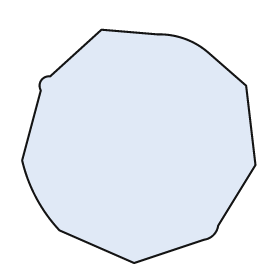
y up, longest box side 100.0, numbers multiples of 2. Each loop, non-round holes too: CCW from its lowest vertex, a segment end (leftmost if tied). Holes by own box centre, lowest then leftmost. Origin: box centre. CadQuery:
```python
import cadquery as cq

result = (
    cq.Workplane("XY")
    .moveTo(-2.0, -50.0)
    .lineTo(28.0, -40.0)
    .threePointArc((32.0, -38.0), (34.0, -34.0))
    .lineTo(50.0, -8.0)
    .lineTo(46.0, 26.0)
    .lineTo(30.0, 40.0)
    .threePointArc((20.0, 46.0), (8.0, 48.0))
    .lineTo(-16.0, 50.0)
    .lineTo(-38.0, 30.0)
    .threePointArc((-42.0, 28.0), (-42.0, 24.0))
    .lineTo(-50.0, -6.0)
    .threePointArc((-44.0, -22.0), (-34.0, -36.0))
    .close()
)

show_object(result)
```